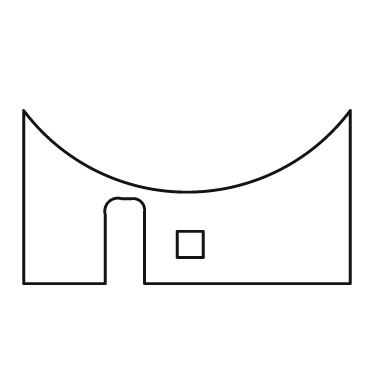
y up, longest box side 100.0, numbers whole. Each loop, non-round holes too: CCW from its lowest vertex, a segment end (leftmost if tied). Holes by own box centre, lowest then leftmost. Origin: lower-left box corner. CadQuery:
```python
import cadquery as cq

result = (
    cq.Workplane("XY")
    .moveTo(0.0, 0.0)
    .lineTo(25.0, 0.0)
    .lineTo(25.0, 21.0)
    .threePointArc((26.0, 25.0), (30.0, 26.0))
    .lineTo(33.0, 26.0)
    .threePointArc((36.0, 25.0), (37.0, 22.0))
    .lineTo(37.0, 0.0)
    .lineTo(100.0, 0.0)
    .lineTo(100.0, 53.0)
    .threePointArc((50.0, 28.0), (0.0, 53.0))
    .close()
    .moveTo(47.0, 8.0)
    .lineTo(55.0, 8.0)
    .lineTo(55.0, 16.0)
    .lineTo(47.0, 16.0)
    .close()
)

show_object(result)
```